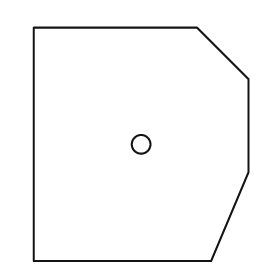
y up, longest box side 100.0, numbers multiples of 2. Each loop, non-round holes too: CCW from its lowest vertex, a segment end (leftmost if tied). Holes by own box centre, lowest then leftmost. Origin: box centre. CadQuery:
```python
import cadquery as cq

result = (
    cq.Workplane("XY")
    .moveTo(-46.0, -50.0)
    .lineTo(30.0, -50.0)
    .lineTo(46.0, -12.0)
    .lineTo(46.0, 28.0)
    .lineTo(24.0, 50.0)
    .lineTo(-46.0, 50.0)
    .close()
    .moveTo(0.0, 0.0)
    .circle(4.0)
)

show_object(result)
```